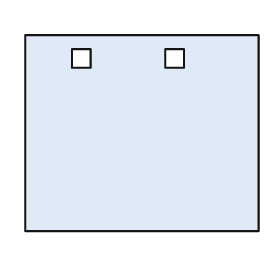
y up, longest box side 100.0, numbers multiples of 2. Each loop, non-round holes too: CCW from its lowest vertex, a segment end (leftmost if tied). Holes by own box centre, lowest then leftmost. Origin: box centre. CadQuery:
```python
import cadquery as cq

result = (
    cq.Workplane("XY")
    .moveTo(-50.0, -42.0)
    .lineTo(50.0, -42.0)
    .lineTo(50.0, 42.0)
    .lineTo(-50.0, 42.0)
    .close()
    .moveTo(-30.0, 28.0)
    .lineTo(-22.0, 28.0)
    .lineTo(-22.0, 36.0)
    .lineTo(-30.0, 36.0)
    .close()
    .moveTo(10.0, 28.0)
    .lineTo(18.0, 28.0)
    .lineTo(18.0, 36.0)
    .lineTo(10.0, 36.0)
    .close()
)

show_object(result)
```